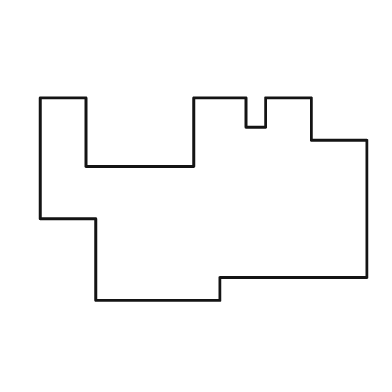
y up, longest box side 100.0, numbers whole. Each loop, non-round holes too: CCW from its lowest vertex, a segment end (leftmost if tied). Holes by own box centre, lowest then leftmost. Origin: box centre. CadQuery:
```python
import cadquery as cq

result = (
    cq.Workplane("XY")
    .moveTo(-33.0, -31.0)
    .lineTo(5.0, -31.0)
    .lineTo(5.0, -24.0)
    .lineTo(50.0, -24.0)
    .lineTo(50.0, 18.0)
    .lineTo(33.0, 18.0)
    .lineTo(33.0, 31.0)
    .lineTo(19.0, 31.0)
    .lineTo(19.0, 22.0)
    .lineTo(13.0, 22.0)
    .lineTo(13.0, 31.0)
    .lineTo(-3.0, 31.0)
    .lineTo(-3.0, 10.0)
    .lineTo(-36.0, 10.0)
    .lineTo(-36.0, 31.0)
    .lineTo(-50.0, 31.0)
    .lineTo(-50.0, -6.0)
    .lineTo(-33.0, -6.0)
    .close()
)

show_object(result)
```